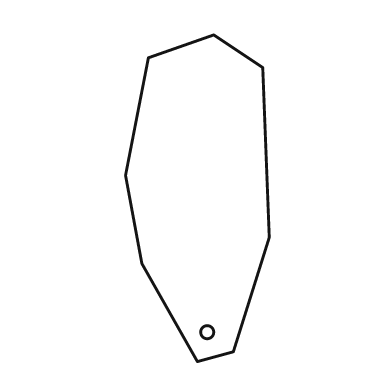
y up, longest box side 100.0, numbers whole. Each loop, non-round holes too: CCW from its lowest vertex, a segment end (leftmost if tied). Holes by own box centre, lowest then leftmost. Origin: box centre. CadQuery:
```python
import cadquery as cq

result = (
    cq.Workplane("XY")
    .moveTo(0.0, -50.0)
    .lineTo(11.0, -47.0)
    .lineTo(22.0, -12.0)
    .lineTo(20.0, 40.0)
    .lineTo(5.0, 50.0)
    .lineTo(-15.0, 43.0)
    .lineTo(-22.0, 7.0)
    .lineTo(-17.0, -20.0)
    .close()
    .moveTo(3.0, -41.0)
    .circle(2.0)
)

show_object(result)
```